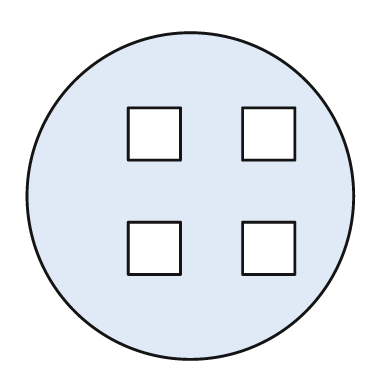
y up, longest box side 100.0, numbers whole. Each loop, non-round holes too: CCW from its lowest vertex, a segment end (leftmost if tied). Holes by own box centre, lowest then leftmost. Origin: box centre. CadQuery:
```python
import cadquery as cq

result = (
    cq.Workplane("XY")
    .moveTo(0.0, 0.0)
    .circle(50.0)
    .moveTo(-19.0, -24.0)
    .lineTo(-3.0, -24.0)
    .lineTo(-3.0, -8.0)
    .lineTo(-19.0, -8.0)
    .close()
    .moveTo(16.0, -24.0)
    .lineTo(32.0, -24.0)
    .lineTo(32.0, -8.0)
    .lineTo(16.0, -8.0)
    .close()
    .moveTo(-19.0, 11.0)
    .lineTo(-3.0, 11.0)
    .lineTo(-3.0, 27.0)
    .lineTo(-19.0, 27.0)
    .close()
    .moveTo(16.0, 11.0)
    .lineTo(32.0, 11.0)
    .lineTo(32.0, 27.0)
    .lineTo(16.0, 27.0)
    .close()
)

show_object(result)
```